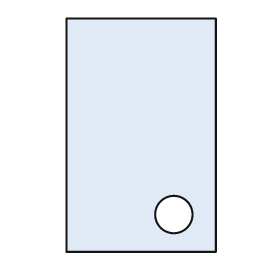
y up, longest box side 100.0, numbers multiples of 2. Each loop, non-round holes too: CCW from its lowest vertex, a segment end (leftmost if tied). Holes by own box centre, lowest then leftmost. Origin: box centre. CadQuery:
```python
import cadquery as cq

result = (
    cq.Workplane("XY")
    .moveTo(-32.0, -50.0)
    .lineTo(32.0, -50.0)
    .lineTo(32.0, 50.0)
    .lineTo(-32.0, 50.0)
    .close()
    .moveTo(14.0, -34.0)
    .circle(8.0)
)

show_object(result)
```